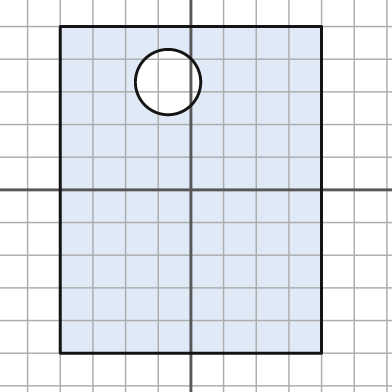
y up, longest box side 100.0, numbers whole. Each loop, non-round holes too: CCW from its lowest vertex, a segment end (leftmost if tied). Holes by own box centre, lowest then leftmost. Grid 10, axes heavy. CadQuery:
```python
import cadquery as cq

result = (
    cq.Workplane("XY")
    .moveTo(-40.0, -50.0)
    .lineTo(40.0, -50.0)
    .lineTo(40.0, 50.0)
    .lineTo(-40.0, 50.0)
    .close()
    .moveTo(-7.0, 33.0)
    .circle(10.0)
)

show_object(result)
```